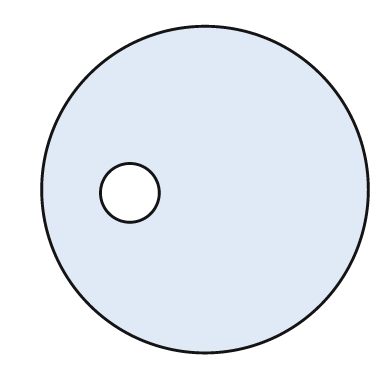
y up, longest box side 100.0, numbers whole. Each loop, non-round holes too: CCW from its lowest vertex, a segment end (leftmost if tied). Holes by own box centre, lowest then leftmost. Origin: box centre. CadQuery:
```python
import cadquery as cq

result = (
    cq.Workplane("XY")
    .moveTo(0.0, 0.0)
    .circle(50.0)
    .moveTo(-23.0, -1.0)
    .circle(9.0)
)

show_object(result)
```